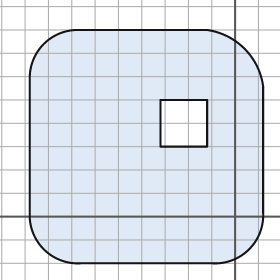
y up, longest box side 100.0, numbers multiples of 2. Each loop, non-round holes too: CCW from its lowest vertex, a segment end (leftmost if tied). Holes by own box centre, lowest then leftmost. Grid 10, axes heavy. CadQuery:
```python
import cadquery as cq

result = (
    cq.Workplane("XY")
    .moveTo(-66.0, -20.0)
    .lineTo(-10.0, -20.0)
    .threePointArc((6.0, -14.0), (12.0, 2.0))
    .lineTo(12.0, 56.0)
    .threePointArc((4.0, 72.0), (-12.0, 80.0))
    .lineTo(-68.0, 80.0)
    .threePointArc((-82.0, 74.0), (-88.0, 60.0))
    .lineTo(-88.0, 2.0)
    .threePointArc((-82.0, -14.0), (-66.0, -20.0))
    .close()
    .moveTo(-32.0, 30.0)
    .lineTo(-12.0, 30.0)
    .lineTo(-12.0, 50.0)
    .lineTo(-32.0, 50.0)
    .close()
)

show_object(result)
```